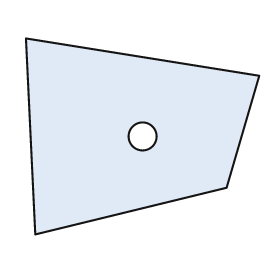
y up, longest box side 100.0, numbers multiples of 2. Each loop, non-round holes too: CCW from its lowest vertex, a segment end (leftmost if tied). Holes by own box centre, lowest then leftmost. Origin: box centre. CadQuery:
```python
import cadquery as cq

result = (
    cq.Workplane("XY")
    .moveTo(-46.0, -42.0)
    .lineTo(36.0, -22.0)
    .lineTo(50.0, 26.0)
    .lineTo(-50.0, 42.0)
    .close()
    .moveTo(0.0, 0.0)
    .circle(6.0)
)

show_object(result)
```